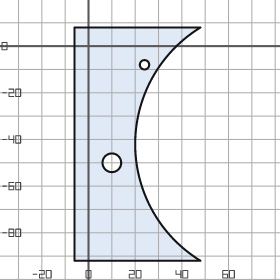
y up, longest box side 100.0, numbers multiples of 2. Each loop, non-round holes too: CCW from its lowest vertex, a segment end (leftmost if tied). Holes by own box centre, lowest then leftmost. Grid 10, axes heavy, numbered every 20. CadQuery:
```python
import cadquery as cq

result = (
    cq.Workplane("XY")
    .moveTo(-6.0, -92.0)
    .lineTo(48.0, -92.0)
    .threePointArc((20.0, -42.0), (48.0, 8.0))
    .lineTo(-6.0, 8.0)
    .close()
    .moveTo(10.0, -50.0)
    .circle(4.0)
    .moveTo(24.0, -8.0)
    .circle(2.0)
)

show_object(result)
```